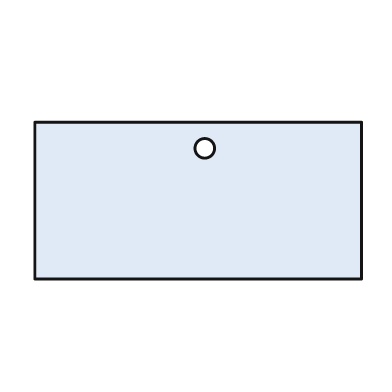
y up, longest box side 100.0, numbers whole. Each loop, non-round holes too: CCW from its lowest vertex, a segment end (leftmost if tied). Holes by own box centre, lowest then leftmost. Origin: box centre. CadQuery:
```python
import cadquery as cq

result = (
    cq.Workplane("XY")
    .moveTo(-50.0, -24.0)
    .lineTo(50.0, -24.0)
    .lineTo(50.0, 24.0)
    .lineTo(-50.0, 24.0)
    .close()
    .moveTo(2.0, 16.0)
    .circle(3.0)
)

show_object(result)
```